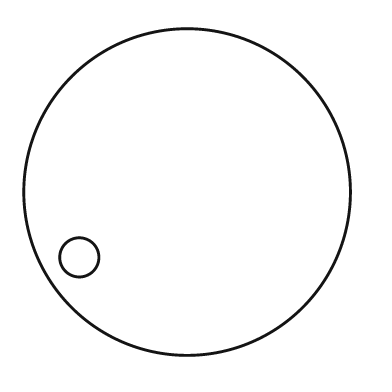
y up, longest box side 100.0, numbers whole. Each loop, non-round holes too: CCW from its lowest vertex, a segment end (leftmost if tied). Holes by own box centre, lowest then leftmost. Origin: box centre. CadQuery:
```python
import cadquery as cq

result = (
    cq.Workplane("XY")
    .moveTo(0.0, 0.0)
    .circle(50.0)
    .moveTo(-33.0, -20.0)
    .circle(6.0)
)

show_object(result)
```